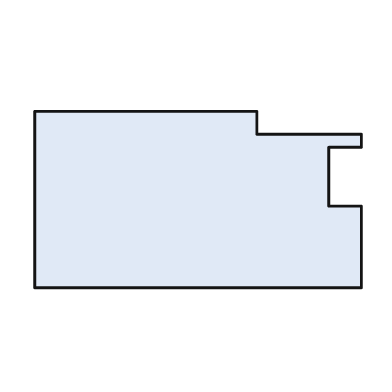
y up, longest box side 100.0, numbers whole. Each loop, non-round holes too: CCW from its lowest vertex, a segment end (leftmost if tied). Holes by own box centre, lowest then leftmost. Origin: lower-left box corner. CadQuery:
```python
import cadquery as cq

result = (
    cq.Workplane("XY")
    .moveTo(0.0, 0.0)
    .lineTo(100.0, 0.0)
    .lineTo(100.0, 25.0)
    .lineTo(90.0, 25.0)
    .lineTo(90.0, 43.0)
    .lineTo(100.0, 43.0)
    .lineTo(100.0, 47.0)
    .lineTo(68.0, 47.0)
    .lineTo(68.0, 54.0)
    .lineTo(0.0, 54.0)
    .close()
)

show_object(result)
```